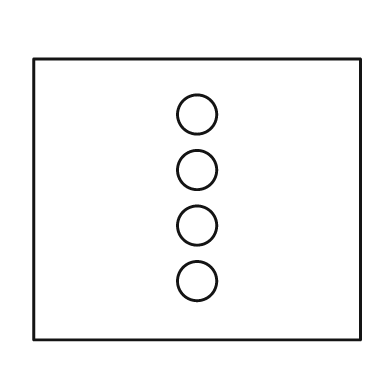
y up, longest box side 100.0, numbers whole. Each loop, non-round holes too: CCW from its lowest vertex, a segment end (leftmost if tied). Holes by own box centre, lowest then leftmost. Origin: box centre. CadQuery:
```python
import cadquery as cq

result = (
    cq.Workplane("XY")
    .moveTo(-50.0, -43.0)
    .lineTo(50.0, -43.0)
    .lineTo(50.0, 43.0)
    .lineTo(-50.0, 43.0)
    .close()
    .moveTo(0.0, -25.0)
    .circle(6.0)
    .moveTo(0.0, -8.0)
    .circle(6.0)
    .moveTo(0.0, 9.0)
    .circle(6.0)
    .moveTo(0.0, 26.0)
    .circle(6.0)
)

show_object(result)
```